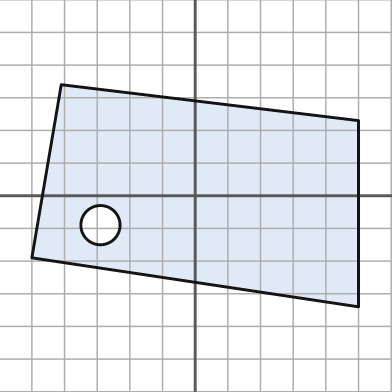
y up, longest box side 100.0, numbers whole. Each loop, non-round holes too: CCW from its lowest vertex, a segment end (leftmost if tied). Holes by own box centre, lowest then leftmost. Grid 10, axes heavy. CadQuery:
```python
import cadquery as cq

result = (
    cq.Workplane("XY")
    .moveTo(50.0, -34.0)
    .lineTo(50.0, 23.0)
    .lineTo(-41.0, 34.0)
    .lineTo(-50.0, -19.0)
    .close()
    .moveTo(-29.0, -9.0)
    .circle(6.0)
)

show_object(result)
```